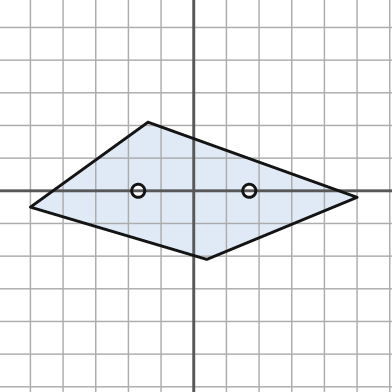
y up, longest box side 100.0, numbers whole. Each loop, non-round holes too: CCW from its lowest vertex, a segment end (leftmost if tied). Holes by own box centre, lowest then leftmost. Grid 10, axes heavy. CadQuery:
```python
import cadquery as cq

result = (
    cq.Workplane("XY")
    .moveTo(4.0, -21.0)
    .lineTo(50.0, -2.0)
    .lineTo(-14.0, 21.0)
    .lineTo(-50.0, -5.0)
    .close()
    .moveTo(-17.0, 0.0)
    .circle(2.0)
    .moveTo(17.0, 0.0)
    .circle(2.0)
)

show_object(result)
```